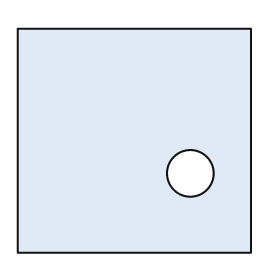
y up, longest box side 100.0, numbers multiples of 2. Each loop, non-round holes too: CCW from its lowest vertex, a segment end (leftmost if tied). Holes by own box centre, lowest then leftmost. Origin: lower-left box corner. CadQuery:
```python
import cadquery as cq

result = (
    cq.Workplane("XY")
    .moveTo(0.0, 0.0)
    .lineTo(100.0, 0.0)
    .lineTo(100.0, 96.0)
    .lineTo(0.0, 96.0)
    .close()
    .moveTo(74.0, 34.0)
    .circle(10.0)
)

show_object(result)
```